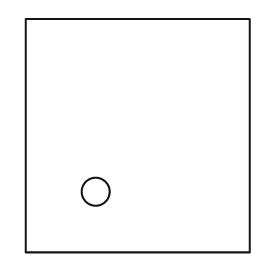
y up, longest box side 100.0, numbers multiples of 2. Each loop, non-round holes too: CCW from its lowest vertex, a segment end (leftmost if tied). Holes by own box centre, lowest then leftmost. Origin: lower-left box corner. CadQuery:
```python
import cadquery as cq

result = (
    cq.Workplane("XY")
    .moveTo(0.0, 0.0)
    .lineTo(96.0, 0.0)
    .lineTo(96.0, 100.0)
    .lineTo(0.0, 100.0)
    .close()
    .moveTo(30.0, 26.0)
    .circle(6.0)
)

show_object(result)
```